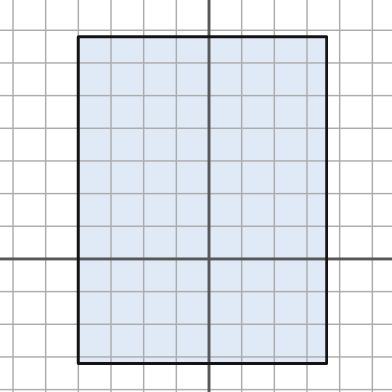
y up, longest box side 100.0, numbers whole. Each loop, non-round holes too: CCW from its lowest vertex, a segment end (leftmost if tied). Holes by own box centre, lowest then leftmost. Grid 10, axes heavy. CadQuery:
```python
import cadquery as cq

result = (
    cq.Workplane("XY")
    .moveTo(-40.0, -32.0)
    .lineTo(36.0, -32.0)
    .lineTo(36.0, 68.0)
    .lineTo(-40.0, 68.0)
    .close()
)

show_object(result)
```